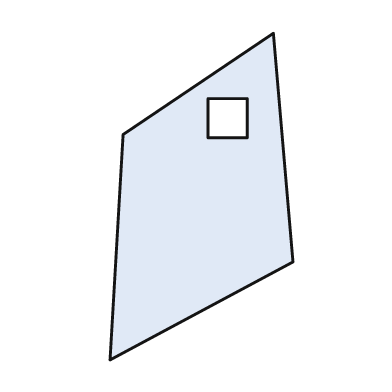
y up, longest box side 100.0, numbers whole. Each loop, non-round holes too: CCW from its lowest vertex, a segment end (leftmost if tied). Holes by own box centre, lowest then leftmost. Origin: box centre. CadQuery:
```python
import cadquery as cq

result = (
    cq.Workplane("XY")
    .moveTo(-28.0, -50.0)
    .lineTo(28.0, -20.0)
    .lineTo(22.0, 50.0)
    .lineTo(-24.0, 19.0)
    .close()
    .moveTo(2.0, 18.0)
    .lineTo(14.0, 18.0)
    .lineTo(14.0, 30.0)
    .lineTo(2.0, 30.0)
    .close()
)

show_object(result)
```